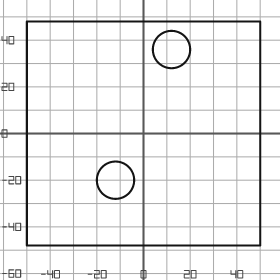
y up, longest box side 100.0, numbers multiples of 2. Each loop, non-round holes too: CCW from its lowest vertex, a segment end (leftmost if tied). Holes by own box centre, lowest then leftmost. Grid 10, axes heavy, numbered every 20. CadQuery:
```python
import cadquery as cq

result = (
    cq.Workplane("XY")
    .moveTo(-50.0, -48.0)
    .lineTo(50.0, -48.0)
    .lineTo(50.0, 48.0)
    .lineTo(-50.0, 48.0)
    .close()
    .moveTo(-12.0, -20.0)
    .circle(8.0)
    .moveTo(12.0, 36.0)
    .circle(8.0)
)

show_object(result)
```